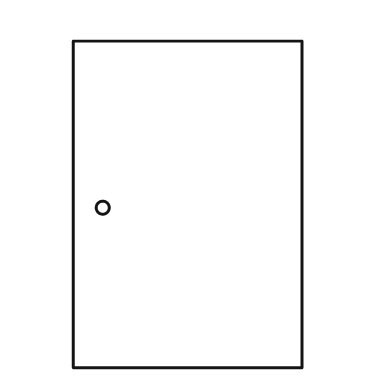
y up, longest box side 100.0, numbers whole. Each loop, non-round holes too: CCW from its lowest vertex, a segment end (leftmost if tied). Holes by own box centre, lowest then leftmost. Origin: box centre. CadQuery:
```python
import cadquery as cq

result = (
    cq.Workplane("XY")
    .moveTo(-35.0, -50.0)
    .lineTo(35.0, -50.0)
    .lineTo(35.0, 50.0)
    .lineTo(-35.0, 50.0)
    .close()
    .moveTo(-26.0, -1.0)
    .circle(2.0)
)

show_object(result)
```